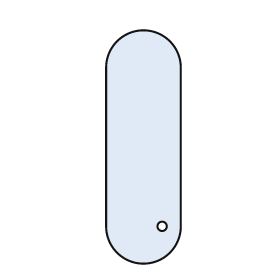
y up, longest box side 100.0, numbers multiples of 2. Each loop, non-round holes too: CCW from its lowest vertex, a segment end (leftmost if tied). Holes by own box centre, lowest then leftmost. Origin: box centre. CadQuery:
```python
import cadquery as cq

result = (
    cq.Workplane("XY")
    .moveTo(-16.0, -34.0)
    .threePointArc((0.0, -50.0), (16.0, -34.0))
    .lineTo(16.0, 34.0)
    .threePointArc((0.0, 50.0), (-16.0, 34.0))
    .close()
    .moveTo(8.0, -34.0)
    .circle(2.0)
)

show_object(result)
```